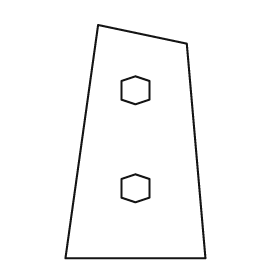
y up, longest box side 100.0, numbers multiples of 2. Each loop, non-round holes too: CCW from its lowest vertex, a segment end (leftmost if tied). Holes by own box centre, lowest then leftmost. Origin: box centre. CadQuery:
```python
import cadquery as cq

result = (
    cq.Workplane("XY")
    .moveTo(-30.0, -50.0)
    .lineTo(30.0, -50.0)
    .lineTo(22.0, 42.0)
    .lineTo(-16.0, 50.0)
    .close()
    .moveTo(0.0, -26.0)
    .lineTo(6.0, -24.0)
    .lineTo(6.0, -16.0)
    .lineTo(0.0, -14.0)
    .lineTo(-6.0, -16.0)
    .lineTo(-6.0, -24.0)
    .close()
    .moveTo(0.0, 16.0)
    .lineTo(6.0, 18.0)
    .lineTo(6.0, 26.0)
    .lineTo(0.0, 28.0)
    .lineTo(-6.0, 26.0)
    .lineTo(-6.0, 18.0)
    .close()
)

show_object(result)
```